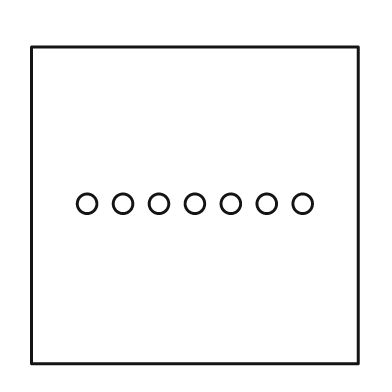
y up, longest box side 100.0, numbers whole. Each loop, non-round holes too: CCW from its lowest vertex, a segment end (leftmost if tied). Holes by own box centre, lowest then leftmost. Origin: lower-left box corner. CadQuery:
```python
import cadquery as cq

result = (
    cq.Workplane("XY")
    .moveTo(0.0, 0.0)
    .lineTo(100.0, 0.0)
    .lineTo(100.0, 97.0)
    .lineTo(0.0, 97.0)
    .close()
    .moveTo(17.0, 49.0)
    .circle(3.0)
    .moveTo(28.0, 49.0)
    .circle(3.0)
    .moveTo(39.0, 49.0)
    .circle(3.0)
    .moveTo(50.0, 49.0)
    .circle(3.0)
    .moveTo(61.0, 49.0)
    .circle(3.0)
    .moveTo(72.0, 49.0)
    .circle(3.0)
    .moveTo(83.0, 49.0)
    .circle(3.0)
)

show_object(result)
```